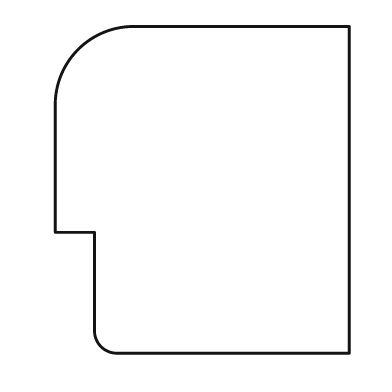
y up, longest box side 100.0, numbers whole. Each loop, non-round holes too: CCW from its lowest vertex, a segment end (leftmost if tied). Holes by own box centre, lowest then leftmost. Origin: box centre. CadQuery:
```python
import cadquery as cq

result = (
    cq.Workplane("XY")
    .moveTo(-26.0, -50.0)
    .lineTo(45.0, -50.0)
    .lineTo(45.0, 50.0)
    .lineTo(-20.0, 50.0)
    .threePointArc((-38.0, 43.0), (-45.0, 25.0))
    .lineTo(-45.0, -13.0)
    .lineTo(-33.0, -13.0)
    .lineTo(-33.0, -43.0)
    .threePointArc((-31.0, -48.0), (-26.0, -50.0))
    .close()
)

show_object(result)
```